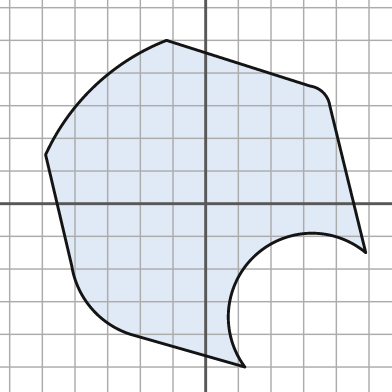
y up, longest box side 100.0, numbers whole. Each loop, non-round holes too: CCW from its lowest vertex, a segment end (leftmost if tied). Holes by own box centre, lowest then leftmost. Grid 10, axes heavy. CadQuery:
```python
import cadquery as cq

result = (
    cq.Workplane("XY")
    .moveTo(12.0, -50.0)
    .threePointArc((15.0, -16.0), (49.0, -15.0))
    .lineTo(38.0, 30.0)
    .threePointArc((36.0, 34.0), (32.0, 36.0))
    .lineTo(-12.0, 50.0)
    .threePointArc((-34.0, 36.0), (-49.0, 15.0))
    .lineTo(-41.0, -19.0)
    .threePointArc((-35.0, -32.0), (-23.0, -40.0))
    .close()
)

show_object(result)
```